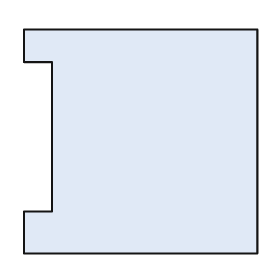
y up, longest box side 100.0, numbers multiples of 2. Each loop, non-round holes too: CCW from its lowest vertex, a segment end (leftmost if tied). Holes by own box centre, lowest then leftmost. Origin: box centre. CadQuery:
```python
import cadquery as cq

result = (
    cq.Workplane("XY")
    .moveTo(-50.0, -48.0)
    .lineTo(50.0, -48.0)
    .lineTo(50.0, 48.0)
    .lineTo(-50.0, 48.0)
    .lineTo(-50.0, 34.0)
    .lineTo(-38.0, 34.0)
    .lineTo(-38.0, -30.0)
    .lineTo(-50.0, -30.0)
    .close()
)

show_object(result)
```